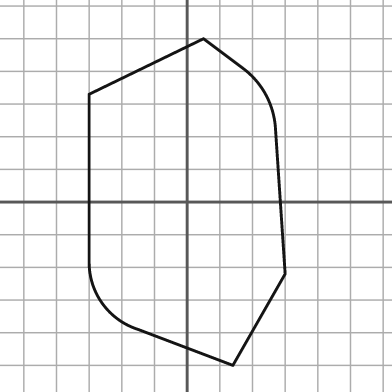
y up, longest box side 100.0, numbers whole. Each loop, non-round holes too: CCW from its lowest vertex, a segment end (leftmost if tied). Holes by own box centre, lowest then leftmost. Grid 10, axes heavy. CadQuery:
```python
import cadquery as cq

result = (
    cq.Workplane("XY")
    .moveTo(14.0, -50.0)
    .lineTo(30.0, -22.0)
    .lineTo(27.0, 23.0)
    .threePointArc((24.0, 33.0), (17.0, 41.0))
    .lineTo(5.0, 50.0)
    .lineTo(-30.0, 33.0)
    .lineTo(-30.0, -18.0)
    .threePointArc((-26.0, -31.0), (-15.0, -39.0))
    .close()
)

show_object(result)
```